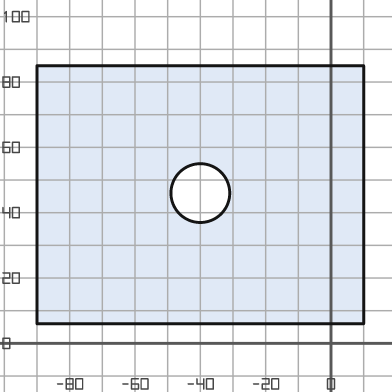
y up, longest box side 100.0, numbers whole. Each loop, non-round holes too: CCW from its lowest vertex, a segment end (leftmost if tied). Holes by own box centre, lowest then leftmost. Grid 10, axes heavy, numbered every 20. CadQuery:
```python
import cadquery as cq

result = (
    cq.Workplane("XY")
    .moveTo(-90.0, 6.0)
    .lineTo(10.0, 6.0)
    .lineTo(10.0, 85.0)
    .lineTo(-90.0, 85.0)
    .close()
    .moveTo(-40.0, 46.0)
    .circle(9.0)
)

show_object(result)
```